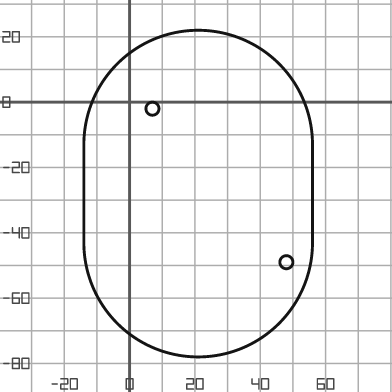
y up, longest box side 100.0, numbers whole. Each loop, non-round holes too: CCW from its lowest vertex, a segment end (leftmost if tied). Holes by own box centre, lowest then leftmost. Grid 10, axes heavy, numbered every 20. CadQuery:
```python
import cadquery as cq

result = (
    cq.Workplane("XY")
    .moveTo(-14.0, -43.0)
    .threePointArc((21.0, -78.0), (56.0, -43.0))
    .lineTo(56.0, -13.0)
    .threePointArc((21.0, 22.0), (-14.0, -13.0))
    .close()
    .moveTo(48.0, -49.0)
    .circle(2.0)
    .moveTo(7.0, -2.0)
    .circle(2.0)
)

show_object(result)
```